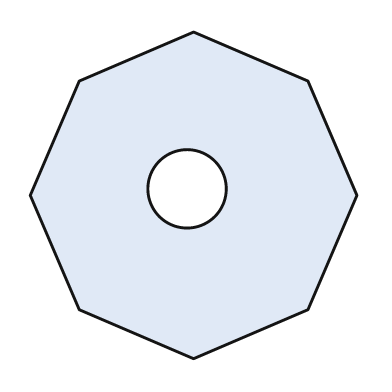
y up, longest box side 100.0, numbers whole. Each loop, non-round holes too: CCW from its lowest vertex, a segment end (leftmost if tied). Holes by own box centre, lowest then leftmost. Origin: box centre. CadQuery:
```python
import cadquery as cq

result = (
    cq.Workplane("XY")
    .moveTo(0.0, -50.0)
    .lineTo(35.0, -35.0)
    .lineTo(50.0, 0.0)
    .lineTo(35.0, 35.0)
    .lineTo(0.0, 50.0)
    .lineTo(-35.0, 35.0)
    .lineTo(-50.0, 0.0)
    .lineTo(-35.0, -35.0)
    .close()
    .moveTo(-2.0, 2.0)
    .circle(12.0)
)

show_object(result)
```